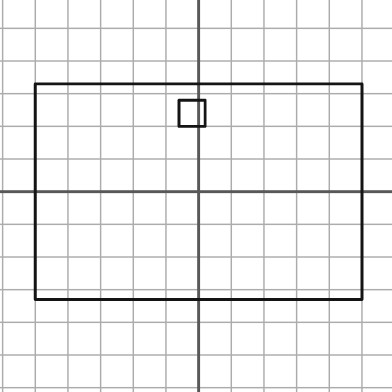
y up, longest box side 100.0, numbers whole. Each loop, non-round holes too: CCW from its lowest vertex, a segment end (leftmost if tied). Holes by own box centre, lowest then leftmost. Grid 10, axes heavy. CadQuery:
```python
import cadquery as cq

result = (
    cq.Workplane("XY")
    .moveTo(-50.0, -33.0)
    .lineTo(50.0, -33.0)
    .lineTo(50.0, 33.0)
    .lineTo(-50.0, 33.0)
    .close()
    .moveTo(-6.0, 20.0)
    .lineTo(2.0, 20.0)
    .lineTo(2.0, 28.0)
    .lineTo(-6.0, 28.0)
    .close()
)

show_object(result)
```